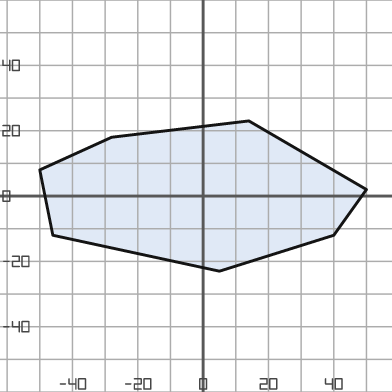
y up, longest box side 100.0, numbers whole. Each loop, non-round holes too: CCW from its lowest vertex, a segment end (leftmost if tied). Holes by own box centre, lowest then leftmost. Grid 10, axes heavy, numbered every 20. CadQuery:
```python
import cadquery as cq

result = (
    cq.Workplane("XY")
    .moveTo(5.0, -23.0)
    .lineTo(40.0, -12.0)
    .lineTo(50.0, 2.0)
    .lineTo(14.0, 23.0)
    .lineTo(-28.0, 18.0)
    .lineTo(-50.0, 8.0)
    .lineTo(-46.0, -12.0)
    .close()
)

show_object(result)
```